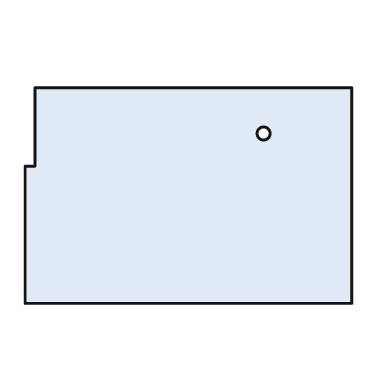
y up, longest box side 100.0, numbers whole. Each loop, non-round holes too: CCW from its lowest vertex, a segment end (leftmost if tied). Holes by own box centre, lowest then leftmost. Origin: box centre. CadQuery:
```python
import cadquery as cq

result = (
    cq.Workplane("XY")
    .moveTo(-50.0, -33.0)
    .lineTo(50.0, -33.0)
    .lineTo(50.0, 33.0)
    .lineTo(-47.0, 33.0)
    .lineTo(-47.0, 9.0)
    .lineTo(-50.0, 9.0)
    .close()
    .moveTo(23.0, 19.0)
    .circle(2.0)
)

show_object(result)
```